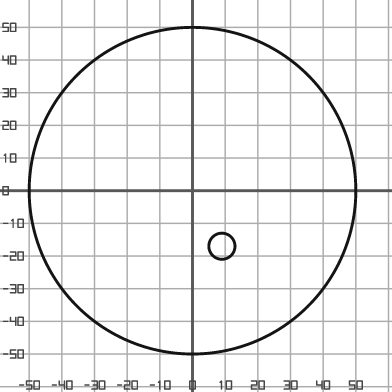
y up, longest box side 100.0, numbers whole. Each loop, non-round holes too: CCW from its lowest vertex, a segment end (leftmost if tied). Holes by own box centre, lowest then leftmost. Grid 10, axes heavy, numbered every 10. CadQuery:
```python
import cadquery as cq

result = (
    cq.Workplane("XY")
    .moveTo(0.0, 0.0)
    .circle(50.0)
    .moveTo(9.0, -17.0)
    .circle(4.0)
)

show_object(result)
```